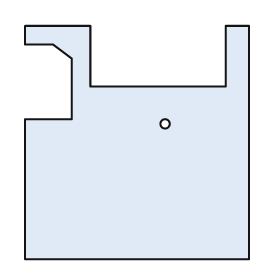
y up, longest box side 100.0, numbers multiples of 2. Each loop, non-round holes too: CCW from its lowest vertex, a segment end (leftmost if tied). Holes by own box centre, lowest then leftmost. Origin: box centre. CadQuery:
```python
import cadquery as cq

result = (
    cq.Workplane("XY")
    .moveTo(-48.0, -50.0)
    .lineTo(48.0, -50.0)
    .lineTo(48.0, 50.0)
    .lineTo(38.0, 50.0)
    .lineTo(38.0, 24.0)
    .lineTo(-20.0, 24.0)
    .lineTo(-20.0, 50.0)
    .lineTo(-48.0, 50.0)
    .lineTo(-48.0, 42.0)
    .lineTo(-36.0, 42.0)
    .lineTo(-28.0, 36.0)
    .lineTo(-28.0, 10.0)
    .lineTo(-48.0, 10.0)
    .close()
    .moveTo(12.0, 8.0)
    .circle(2.0)
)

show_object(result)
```